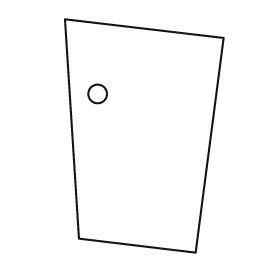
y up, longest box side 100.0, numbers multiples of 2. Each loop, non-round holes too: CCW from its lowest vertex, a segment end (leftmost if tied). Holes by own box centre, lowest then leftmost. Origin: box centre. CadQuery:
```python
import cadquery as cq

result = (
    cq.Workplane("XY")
    .moveTo(22.0, -50.0)
    .lineTo(34.0, 42.0)
    .lineTo(-34.0, 50.0)
    .lineTo(-28.0, -44.0)
    .close()
    .moveTo(-20.0, 18.0)
    .circle(4.0)
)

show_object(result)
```